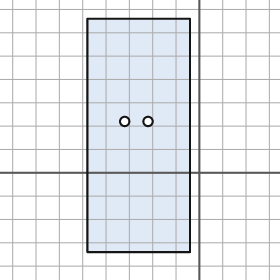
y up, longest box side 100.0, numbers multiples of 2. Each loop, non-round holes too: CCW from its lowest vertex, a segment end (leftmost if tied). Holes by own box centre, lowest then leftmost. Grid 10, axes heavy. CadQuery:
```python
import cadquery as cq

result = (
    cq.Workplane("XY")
    .moveTo(-48.0, -34.0)
    .lineTo(-4.0, -34.0)
    .lineTo(-4.0, 66.0)
    .lineTo(-48.0, 66.0)
    .close()
    .moveTo(-32.0, 22.0)
    .circle(2.0)
    .moveTo(-22.0, 22.0)
    .circle(2.0)
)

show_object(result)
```